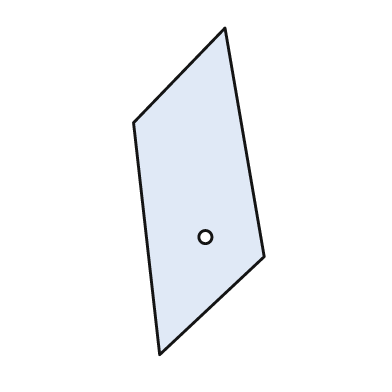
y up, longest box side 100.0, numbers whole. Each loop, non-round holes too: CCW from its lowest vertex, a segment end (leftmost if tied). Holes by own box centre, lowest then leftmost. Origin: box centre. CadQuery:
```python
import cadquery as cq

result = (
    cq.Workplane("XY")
    .moveTo(-12.0, -50.0)
    .lineTo(20.0, -20.0)
    .lineTo(8.0, 50.0)
    .lineTo(-20.0, 21.0)
    .close()
    .moveTo(2.0, -14.0)
    .circle(2.0)
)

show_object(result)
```